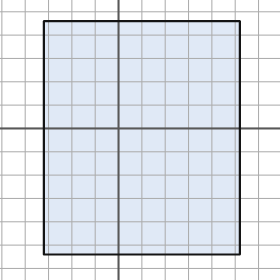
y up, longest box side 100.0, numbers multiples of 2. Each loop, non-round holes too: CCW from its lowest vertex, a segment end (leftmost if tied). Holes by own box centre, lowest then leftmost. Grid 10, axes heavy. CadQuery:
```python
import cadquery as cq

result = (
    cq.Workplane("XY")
    .moveTo(-32.0, -54.0)
    .lineTo(52.0, -54.0)
    .lineTo(52.0, 46.0)
    .lineTo(-32.0, 46.0)
    .close()
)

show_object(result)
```